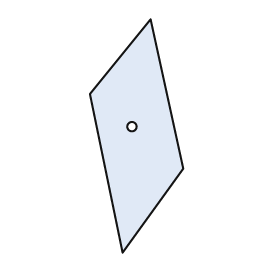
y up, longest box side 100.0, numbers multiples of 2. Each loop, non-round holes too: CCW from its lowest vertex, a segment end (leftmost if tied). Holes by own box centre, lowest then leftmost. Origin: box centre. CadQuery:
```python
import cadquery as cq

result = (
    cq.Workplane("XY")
    .moveTo(-6.0, -50.0)
    .lineTo(20.0, -14.0)
    .lineTo(6.0, 50.0)
    .lineTo(-20.0, 18.0)
    .close()
    .moveTo(-2.0, 4.0)
    .circle(2.0)
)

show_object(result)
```